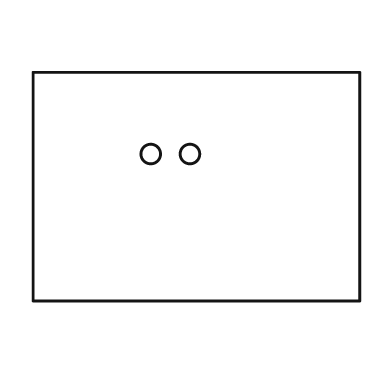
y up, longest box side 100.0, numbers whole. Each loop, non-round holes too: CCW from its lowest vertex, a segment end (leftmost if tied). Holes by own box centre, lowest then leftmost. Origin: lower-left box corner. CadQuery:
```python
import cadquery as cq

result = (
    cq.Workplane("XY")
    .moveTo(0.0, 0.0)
    .lineTo(100.0, 0.0)
    .lineTo(100.0, 70.0)
    .lineTo(0.0, 70.0)
    .close()
    .moveTo(36.0, 45.0)
    .circle(3.0)
    .moveTo(48.0, 45.0)
    .circle(3.0)
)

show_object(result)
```